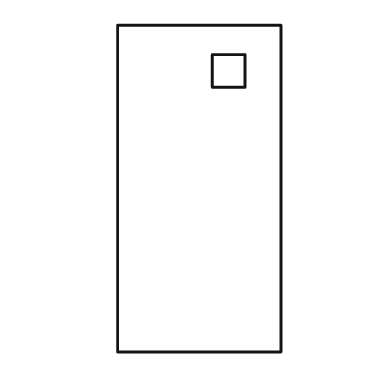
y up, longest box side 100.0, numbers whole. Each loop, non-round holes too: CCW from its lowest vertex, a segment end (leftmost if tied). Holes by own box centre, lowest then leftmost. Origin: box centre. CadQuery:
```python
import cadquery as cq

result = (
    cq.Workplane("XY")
    .moveTo(-25.0, -50.0)
    .lineTo(25.0, -50.0)
    .lineTo(25.0, 50.0)
    .lineTo(-25.0, 50.0)
    .close()
    .moveTo(4.0, 31.0)
    .lineTo(14.0, 31.0)
    .lineTo(14.0, 41.0)
    .lineTo(4.0, 41.0)
    .close()
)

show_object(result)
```